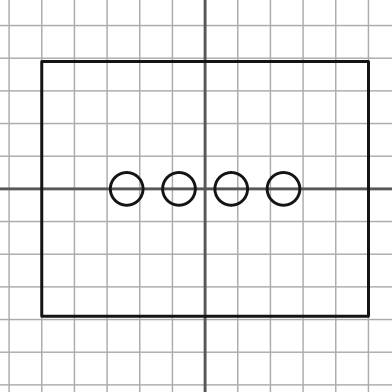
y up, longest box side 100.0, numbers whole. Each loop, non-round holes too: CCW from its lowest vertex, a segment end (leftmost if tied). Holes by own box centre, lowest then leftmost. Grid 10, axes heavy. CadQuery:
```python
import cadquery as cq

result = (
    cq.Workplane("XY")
    .moveTo(-50.0, -39.0)
    .lineTo(50.0, -39.0)
    .lineTo(50.0, 39.0)
    .lineTo(-50.0, 39.0)
    .close()
    .moveTo(-24.0, 0.0)
    .circle(5.0)
    .moveTo(-8.0, 0.0)
    .circle(5.0)
    .moveTo(8.0, 0.0)
    .circle(5.0)
    .moveTo(24.0, 0.0)
    .circle(5.0)
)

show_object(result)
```